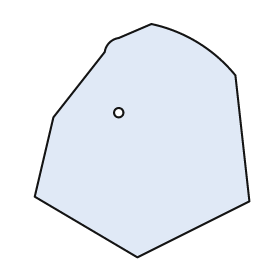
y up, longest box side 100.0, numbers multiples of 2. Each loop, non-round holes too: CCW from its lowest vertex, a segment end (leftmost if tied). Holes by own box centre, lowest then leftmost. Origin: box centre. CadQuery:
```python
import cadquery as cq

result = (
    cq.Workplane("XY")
    .moveTo(-2.0, -50.0)
    .lineTo(46.0, -26.0)
    .lineTo(40.0, 28.0)
    .threePointArc((24.0, 42.0), (4.0, 50.0))
    .lineTo(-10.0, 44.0)
    .threePointArc((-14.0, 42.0), (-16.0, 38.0))
    .lineTo(-38.0, 10.0)
    .lineTo(-46.0, -24.0)
    .close()
    .moveTo(-10.0, 12.0)
    .circle(2.0)
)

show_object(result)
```